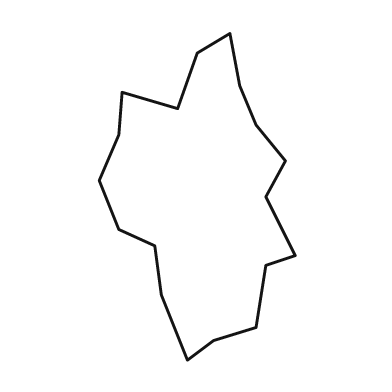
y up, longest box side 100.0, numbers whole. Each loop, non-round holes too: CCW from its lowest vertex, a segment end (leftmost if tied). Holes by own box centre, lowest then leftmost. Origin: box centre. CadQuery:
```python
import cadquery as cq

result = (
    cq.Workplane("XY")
    .moveTo(-3.0, -50.0)
    .lineTo(5.0, -44.0)
    .lineTo(18.0, -40.0)
    .lineTo(21.0, -21.0)
    .lineTo(30.0, -18.0)
    .lineTo(21.0, 0.0)
    .lineTo(27.0, 11.0)
    .lineTo(18.0, 22.0)
    .lineTo(13.0, 34.0)
    .lineTo(10.0, 50.0)
    .lineTo(0.0, 44.0)
    .lineTo(-6.0, 27.0)
    .lineTo(-23.0, 32.0)
    .lineTo(-24.0, 19.0)
    .lineTo(-30.0, 5.0)
    .lineTo(-24.0, -10.0)
    .lineTo(-13.0, -15.0)
    .lineTo(-11.0, -30.0)
    .close()
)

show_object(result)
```